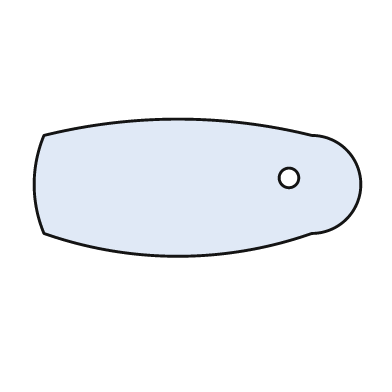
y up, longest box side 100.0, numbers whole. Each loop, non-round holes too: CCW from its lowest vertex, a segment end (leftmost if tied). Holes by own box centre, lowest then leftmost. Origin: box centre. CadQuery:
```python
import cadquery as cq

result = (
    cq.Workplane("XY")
    .moveTo(-47.0, -14.0)
    .threePointArc((-6.0, -21.0), (35.0, -14.0))
    .threePointArc((50.0, 1.0), (35.0, 16.0))
    .threePointArc((-6.0, 21.0), (-47.0, 16.0))
    .threePointArc((-50.0, 1.0), (-47.0, -14.0))
    .close()
    .moveTo(28.0, 3.0)
    .circle(3.0)
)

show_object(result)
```